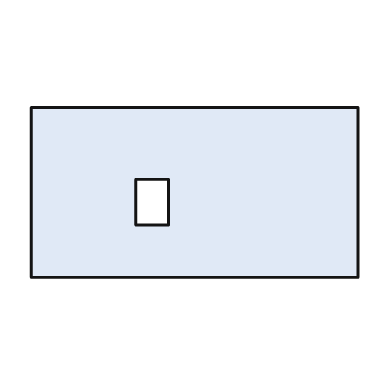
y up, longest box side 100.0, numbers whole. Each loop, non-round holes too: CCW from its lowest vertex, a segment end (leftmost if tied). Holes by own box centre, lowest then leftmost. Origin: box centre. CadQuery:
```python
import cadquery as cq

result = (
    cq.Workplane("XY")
    .moveTo(-50.0, -26.0)
    .lineTo(50.0, -26.0)
    .lineTo(50.0, 26.0)
    .lineTo(-50.0, 26.0)
    .close()
    .moveTo(-18.0, -10.0)
    .lineTo(-8.0, -10.0)
    .lineTo(-8.0, 4.0)
    .lineTo(-18.0, 4.0)
    .close()
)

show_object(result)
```